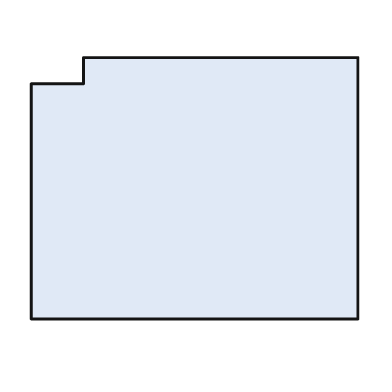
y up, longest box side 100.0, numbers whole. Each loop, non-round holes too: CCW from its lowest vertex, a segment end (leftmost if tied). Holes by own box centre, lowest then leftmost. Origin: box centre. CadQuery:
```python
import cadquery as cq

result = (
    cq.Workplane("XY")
    .moveTo(-50.0, -40.0)
    .lineTo(50.0, -40.0)
    .lineTo(50.0, 40.0)
    .lineTo(-34.0, 40.0)
    .lineTo(-34.0, 32.0)
    .lineTo(-50.0, 32.0)
    .close()
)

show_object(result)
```